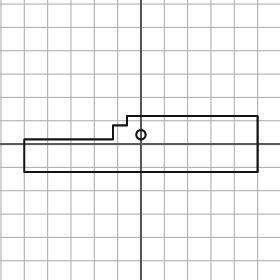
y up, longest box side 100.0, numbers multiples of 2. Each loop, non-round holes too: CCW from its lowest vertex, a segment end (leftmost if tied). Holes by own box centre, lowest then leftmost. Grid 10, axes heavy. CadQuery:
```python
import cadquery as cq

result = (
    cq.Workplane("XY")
    .moveTo(-50.0, -12.0)
    .lineTo(50.0, -12.0)
    .lineTo(50.0, 12.0)
    .lineTo(-6.0, 12.0)
    .lineTo(-6.0, 8.0)
    .lineTo(-12.0, 8.0)
    .lineTo(-12.0, 2.0)
    .lineTo(-50.0, 2.0)
    .close()
    .moveTo(0.0, 4.0)
    .circle(2.0)
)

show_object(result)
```